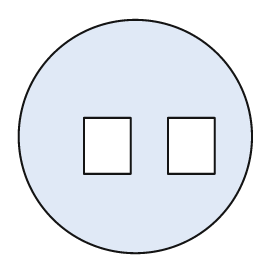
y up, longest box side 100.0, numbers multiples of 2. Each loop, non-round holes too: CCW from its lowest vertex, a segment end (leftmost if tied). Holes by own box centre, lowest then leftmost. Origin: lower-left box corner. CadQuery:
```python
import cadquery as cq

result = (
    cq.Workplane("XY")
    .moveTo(50.0, 50.0)
    .circle(50.0)
    .moveTo(28.0, 34.0)
    .lineTo(48.0, 34.0)
    .lineTo(48.0, 58.0)
    .lineTo(28.0, 58.0)
    .close()
    .moveTo(64.0, 34.0)
    .lineTo(84.0, 34.0)
    .lineTo(84.0, 58.0)
    .lineTo(64.0, 58.0)
    .close()
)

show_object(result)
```